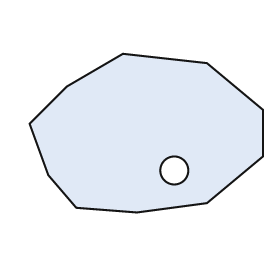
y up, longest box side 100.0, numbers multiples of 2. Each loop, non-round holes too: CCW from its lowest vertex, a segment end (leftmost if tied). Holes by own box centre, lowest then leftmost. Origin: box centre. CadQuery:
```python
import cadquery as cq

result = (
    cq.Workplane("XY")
    .moveTo(-4.0, -34.0)
    .lineTo(26.0, -30.0)
    .lineTo(50.0, -10.0)
    .lineTo(50.0, 10.0)
    .lineTo(26.0, 30.0)
    .lineTo(-10.0, 34.0)
    .lineTo(-34.0, 20.0)
    .lineTo(-50.0, 4.0)
    .lineTo(-42.0, -18.0)
    .lineTo(-30.0, -32.0)
    .close()
    .moveTo(12.0, -16.0)
    .circle(6.0)
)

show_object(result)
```